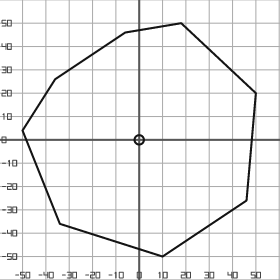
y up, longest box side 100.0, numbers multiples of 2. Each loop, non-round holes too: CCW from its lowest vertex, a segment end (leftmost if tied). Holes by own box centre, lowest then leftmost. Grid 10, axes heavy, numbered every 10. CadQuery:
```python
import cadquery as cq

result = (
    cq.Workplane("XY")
    .moveTo(10.0, -50.0)
    .lineTo(46.0, -26.0)
    .lineTo(50.0, 20.0)
    .lineTo(18.0, 50.0)
    .lineTo(-6.0, 46.0)
    .lineTo(-36.0, 26.0)
    .lineTo(-50.0, 4.0)
    .lineTo(-34.0, -36.0)
    .close()
    .moveTo(0.0, 0.0)
    .circle(2.0)
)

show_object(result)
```